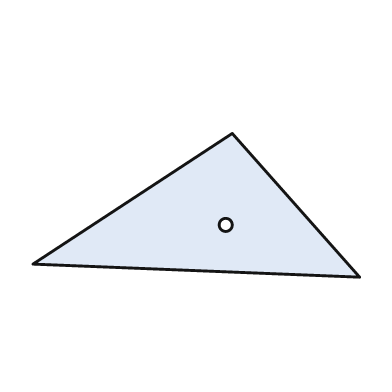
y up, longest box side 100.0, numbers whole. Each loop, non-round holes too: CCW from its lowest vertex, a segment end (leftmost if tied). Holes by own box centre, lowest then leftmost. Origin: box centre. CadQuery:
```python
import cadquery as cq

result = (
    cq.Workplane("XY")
    .moveTo(50.0, -22.0)
    .lineTo(11.0, 22.0)
    .lineTo(-50.0, -18.0)
    .close()
    .moveTo(9.0, -6.0)
    .circle(2.0)
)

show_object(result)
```